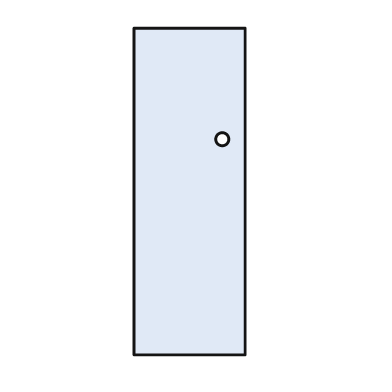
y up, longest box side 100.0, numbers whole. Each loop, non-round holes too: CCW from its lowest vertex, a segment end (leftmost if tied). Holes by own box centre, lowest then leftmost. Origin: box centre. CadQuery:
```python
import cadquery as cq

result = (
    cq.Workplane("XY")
    .moveTo(-17.0, -50.0)
    .lineTo(17.0, -50.0)
    .lineTo(17.0, 50.0)
    .lineTo(-17.0, 50.0)
    .close()
    .moveTo(10.0, 16.0)
    .circle(2.0)
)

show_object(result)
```